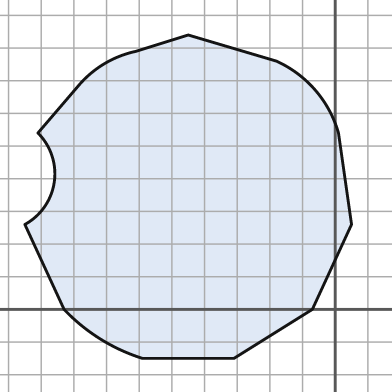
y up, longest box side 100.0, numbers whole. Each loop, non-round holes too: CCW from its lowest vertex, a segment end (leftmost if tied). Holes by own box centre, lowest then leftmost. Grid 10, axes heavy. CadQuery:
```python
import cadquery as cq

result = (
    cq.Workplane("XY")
    .moveTo(-59.0, -15.0)
    .lineTo(-31.0, -15.0)
    .lineTo(-7.0, 0.0)
    .lineTo(5.0, 26.0)
    .lineTo(1.0, 54.0)
    .threePointArc((-6.0, 67.0), (-18.0, 76.0))
    .lineTo(-45.0, 84.0)
    .lineTo(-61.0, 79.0)
    .threePointArc((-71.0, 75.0), (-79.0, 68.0))
    .lineTo(-91.0, 54.0)
    .threePointArc((-86.0, 39.0), (-95.0, 26.0))
    .lineTo(-83.0, 0.0)
    .threePointArc((-72.0, -9.0), (-59.0, -15.0))
    .close()
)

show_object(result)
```